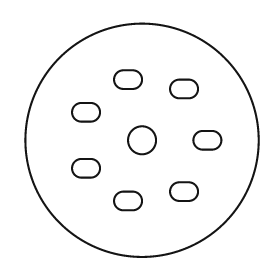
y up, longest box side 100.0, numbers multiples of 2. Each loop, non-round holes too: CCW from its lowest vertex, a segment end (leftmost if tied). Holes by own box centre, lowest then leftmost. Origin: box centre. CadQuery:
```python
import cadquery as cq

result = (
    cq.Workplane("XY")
    .moveTo(0.0, 0.0)
    .circle(50.0)
    .moveTo(-8.0, -30.0)
    .lineTo(-4.0, -30.0)
    .threePointArc((0.0, -26.0), (-4.0, -22.0))
    .lineTo(-8.0, -22.0)
    .threePointArc((-12.0, -26.0), (-8.0, -30.0))
    .close()
    .moveTo(16.0, -26.0)
    .lineTo(20.0, -26.0)
    .threePointArc((24.0, -22.0), (20.0, -18.0))
    .lineTo(16.0, -18.0)
    .threePointArc((12.0, -22.0), (16.0, -26.0))
    .close()
    .moveTo(-26.0, -16.0)
    .lineTo(-22.0, -16.0)
    .threePointArc((-18.0, -12.0), (-22.0, -8.0))
    .lineTo(-26.0, -8.0)
    .threePointArc((-30.0, -12.0), (-26.0, -16.0))
    .close()
    .moveTo(0.0, 0.0)
    .circle(6.0)
    .moveTo(26.0, -4.0)
    .lineTo(30.0, -4.0)
    .threePointArc((34.0, 0.0), (30.0, 4.0))
    .lineTo(26.0, 4.0)
    .threePointArc((22.0, 0.0), (26.0, -4.0))
    .close()
    .moveTo(-26.0, 8.0)
    .lineTo(-22.0, 8.0)
    .threePointArc((-18.0, 12.0), (-22.0, 16.0))
    .lineTo(-26.0, 16.0)
    .threePointArc((-30.0, 12.0), (-26.0, 8.0))
    .close()
    .moveTo(16.0, 18.0)
    .lineTo(20.0, 18.0)
    .threePointArc((24.0, 22.0), (20.0, 26.0))
    .lineTo(16.0, 26.0)
    .threePointArc((12.0, 22.0), (16.0, 18.0))
    .close()
    .moveTo(-8.0, 22.0)
    .lineTo(-4.0, 22.0)
    .threePointArc((0.0, 26.0), (-4.0, 30.0))
    .lineTo(-8.0, 30.0)
    .threePointArc((-12.0, 26.0), (-8.0, 22.0))
    .close()
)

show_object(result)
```